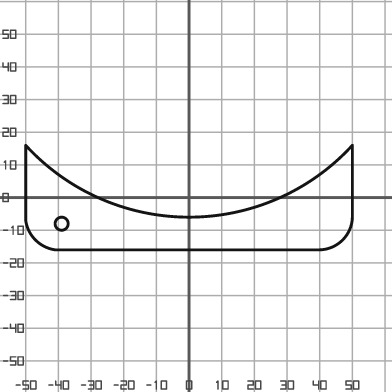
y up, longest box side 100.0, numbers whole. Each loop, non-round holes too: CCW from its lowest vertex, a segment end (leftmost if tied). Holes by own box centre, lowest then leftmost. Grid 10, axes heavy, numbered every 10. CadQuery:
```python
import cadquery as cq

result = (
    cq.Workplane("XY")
    .moveTo(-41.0, -16.0)
    .lineTo(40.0, -16.0)
    .threePointArc((47.0, -13.0), (50.0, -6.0))
    .lineTo(50.0, 16.0)
    .threePointArc((0.0, -6.0), (-50.0, 16.0))
    .lineTo(-50.0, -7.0)
    .threePointArc((-47.0, -13.0), (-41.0, -16.0))
    .close()
    .moveTo(-39.0, -8.0)
    .circle(2.0)
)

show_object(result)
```